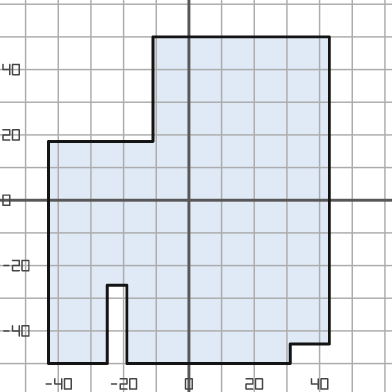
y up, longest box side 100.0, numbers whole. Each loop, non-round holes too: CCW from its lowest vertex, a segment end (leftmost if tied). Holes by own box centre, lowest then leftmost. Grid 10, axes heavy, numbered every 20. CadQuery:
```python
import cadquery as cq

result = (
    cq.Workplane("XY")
    .moveTo(-43.0, -50.0)
    .lineTo(-25.0, -50.0)
    .lineTo(-25.0, -26.0)
    .lineTo(-19.0, -26.0)
    .lineTo(-19.0, -50.0)
    .lineTo(31.0, -50.0)
    .lineTo(31.0, -44.0)
    .lineTo(43.0, -44.0)
    .lineTo(43.0, 50.0)
    .lineTo(-11.0, 50.0)
    .lineTo(-11.0, 18.0)
    .lineTo(-43.0, 18.0)
    .close()
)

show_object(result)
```